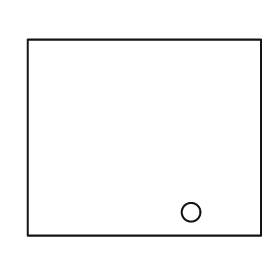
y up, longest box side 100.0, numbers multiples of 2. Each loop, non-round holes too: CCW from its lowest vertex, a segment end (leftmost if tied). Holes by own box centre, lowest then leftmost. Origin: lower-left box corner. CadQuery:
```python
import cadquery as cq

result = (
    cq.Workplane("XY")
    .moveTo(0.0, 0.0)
    .lineTo(100.0, 0.0)
    .lineTo(100.0, 84.0)
    .lineTo(0.0, 84.0)
    .close()
    .moveTo(70.0, 10.0)
    .circle(4.0)
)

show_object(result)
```